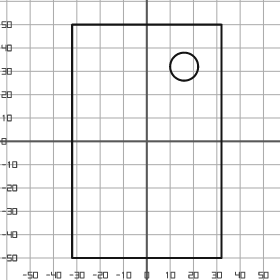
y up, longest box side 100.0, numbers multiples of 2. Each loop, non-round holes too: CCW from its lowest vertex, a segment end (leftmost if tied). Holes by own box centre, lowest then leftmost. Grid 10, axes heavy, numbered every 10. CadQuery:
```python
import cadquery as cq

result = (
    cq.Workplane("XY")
    .moveTo(-32.0, -50.0)
    .lineTo(32.0, -50.0)
    .lineTo(32.0, 50.0)
    .lineTo(-32.0, 50.0)
    .close()
    .moveTo(16.0, 32.0)
    .circle(6.0)
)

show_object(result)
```